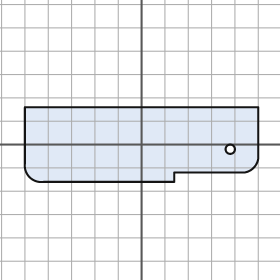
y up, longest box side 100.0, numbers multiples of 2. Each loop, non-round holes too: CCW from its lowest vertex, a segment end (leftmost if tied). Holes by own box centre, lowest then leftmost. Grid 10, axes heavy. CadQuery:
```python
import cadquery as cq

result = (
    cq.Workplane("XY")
    .moveTo(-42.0, -16.0)
    .lineTo(14.0, -16.0)
    .lineTo(14.0, -12.0)
    .lineTo(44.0, -12.0)
    .threePointArc((48.0, -10.0), (50.0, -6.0))
    .lineTo(50.0, 16.0)
    .lineTo(-50.0, 16.0)
    .lineTo(-50.0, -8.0)
    .threePointArc((-48.0, -14.0), (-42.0, -16.0))
    .close()
    .moveTo(38.0, -2.0)
    .circle(2.0)
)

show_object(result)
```